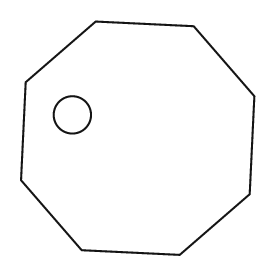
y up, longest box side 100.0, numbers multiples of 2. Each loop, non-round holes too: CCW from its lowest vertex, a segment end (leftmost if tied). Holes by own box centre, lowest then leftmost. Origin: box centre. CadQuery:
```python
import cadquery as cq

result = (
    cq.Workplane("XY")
    .moveTo(18.0, -50.0)
    .lineTo(48.0, -24.0)
    .lineTo(50.0, 18.0)
    .lineTo(24.0, 48.0)
    .lineTo(-18.0, 50.0)
    .lineTo(-48.0, 24.0)
    .lineTo(-50.0, -18.0)
    .lineTo(-24.0, -48.0)
    .close()
    .moveTo(-28.0, 10.0)
    .circle(8.0)
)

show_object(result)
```